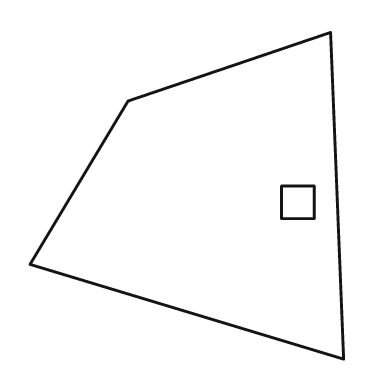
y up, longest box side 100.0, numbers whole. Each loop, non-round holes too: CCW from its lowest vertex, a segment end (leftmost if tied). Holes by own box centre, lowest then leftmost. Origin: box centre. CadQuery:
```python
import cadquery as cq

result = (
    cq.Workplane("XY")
    .moveTo(48.0, -50.0)
    .lineTo(44.0, 50.0)
    .lineTo(-18.0, 29.0)
    .lineTo(-48.0, -21.0)
    .close()
    .moveTo(29.0, -7.0)
    .lineTo(39.0, -7.0)
    .lineTo(39.0, 3.0)
    .lineTo(29.0, 3.0)
    .close()
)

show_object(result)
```